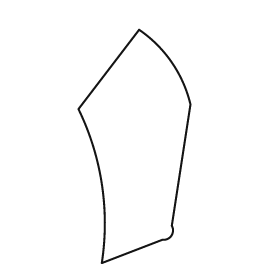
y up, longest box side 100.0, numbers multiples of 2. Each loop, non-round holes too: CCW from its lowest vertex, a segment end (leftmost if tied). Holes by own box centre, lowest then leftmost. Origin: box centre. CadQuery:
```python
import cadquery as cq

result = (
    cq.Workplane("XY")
    .moveTo(-14.0, -50.0)
    .lineTo(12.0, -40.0)
    .threePointArc((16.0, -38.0), (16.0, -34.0))
    .lineTo(24.0, 18.0)
    .threePointArc((16.0, 36.0), (2.0, 50.0))
    .lineTo(-24.0, 16.0)
    .threePointArc((-14.0, -16.0), (-14.0, -50.0))
    .close()
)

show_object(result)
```